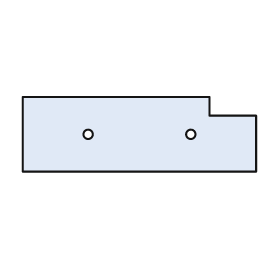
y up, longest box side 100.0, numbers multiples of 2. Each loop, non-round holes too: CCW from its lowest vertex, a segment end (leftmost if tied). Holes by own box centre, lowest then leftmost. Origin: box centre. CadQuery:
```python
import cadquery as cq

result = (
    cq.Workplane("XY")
    .moveTo(-50.0, -16.0)
    .lineTo(50.0, -16.0)
    .lineTo(50.0, 8.0)
    .lineTo(30.0, 8.0)
    .lineTo(30.0, 16.0)
    .lineTo(-50.0, 16.0)
    .close()
    .moveTo(-22.0, 0.0)
    .circle(2.0)
    .moveTo(22.0, 0.0)
    .circle(2.0)
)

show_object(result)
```